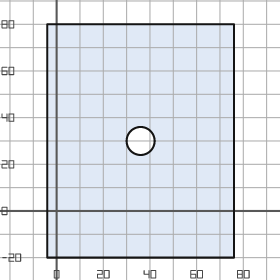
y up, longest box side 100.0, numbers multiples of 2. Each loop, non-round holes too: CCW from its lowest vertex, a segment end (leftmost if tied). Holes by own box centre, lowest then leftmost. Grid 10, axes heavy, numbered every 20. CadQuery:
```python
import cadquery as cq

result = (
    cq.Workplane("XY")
    .moveTo(-4.0, -20.0)
    .lineTo(76.0, -20.0)
    .lineTo(76.0, 80.0)
    .lineTo(-4.0, 80.0)
    .close()
    .moveTo(36.0, 30.0)
    .circle(6.0)
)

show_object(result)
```